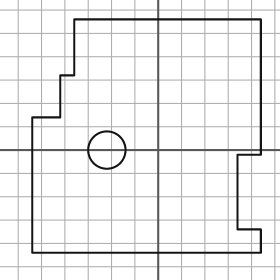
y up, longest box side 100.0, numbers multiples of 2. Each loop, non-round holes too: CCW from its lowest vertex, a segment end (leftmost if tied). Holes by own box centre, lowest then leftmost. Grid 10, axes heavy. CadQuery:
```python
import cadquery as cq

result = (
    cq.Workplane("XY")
    .moveTo(-54.0, -44.0)
    .lineTo(44.0, -44.0)
    .lineTo(44.0, -34.0)
    .lineTo(34.0, -34.0)
    .lineTo(34.0, -2.0)
    .lineTo(44.0, -2.0)
    .lineTo(44.0, 56.0)
    .lineTo(-36.0, 56.0)
    .lineTo(-36.0, 32.0)
    .lineTo(-42.0, 32.0)
    .lineTo(-42.0, 14.0)
    .lineTo(-54.0, 14.0)
    .close()
    .moveTo(-22.0, 0.0)
    .circle(8.0)
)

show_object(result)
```